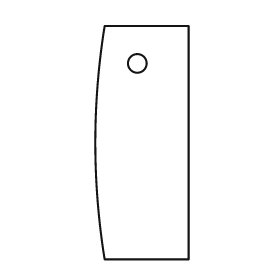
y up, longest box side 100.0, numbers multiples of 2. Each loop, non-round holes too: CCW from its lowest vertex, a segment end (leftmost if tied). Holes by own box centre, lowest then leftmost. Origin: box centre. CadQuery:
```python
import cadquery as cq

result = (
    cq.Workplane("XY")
    .moveTo(-16.0, -50.0)
    .lineTo(20.0, -50.0)
    .lineTo(20.0, 50.0)
    .lineTo(-16.0, 50.0)
    .threePointArc((-20.0, 0.0), (-16.0, -50.0))
    .close()
    .moveTo(-2.0, 34.0)
    .circle(4.0)
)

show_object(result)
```